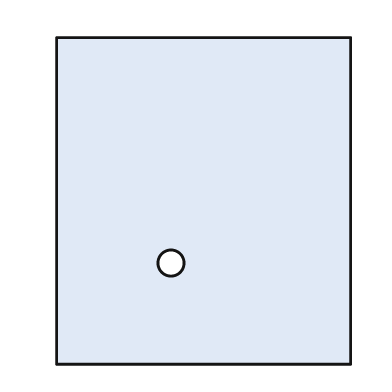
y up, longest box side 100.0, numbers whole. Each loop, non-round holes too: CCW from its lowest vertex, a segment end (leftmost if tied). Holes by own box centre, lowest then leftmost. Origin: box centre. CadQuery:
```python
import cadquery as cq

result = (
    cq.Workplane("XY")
    .moveTo(-45.0, -50.0)
    .lineTo(45.0, -50.0)
    .lineTo(45.0, 50.0)
    .lineTo(-45.0, 50.0)
    .close()
    .moveTo(-10.0, -19.0)
    .circle(4.0)
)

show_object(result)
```